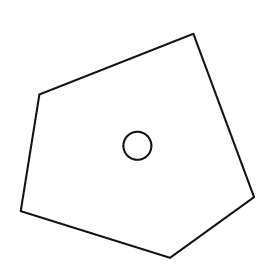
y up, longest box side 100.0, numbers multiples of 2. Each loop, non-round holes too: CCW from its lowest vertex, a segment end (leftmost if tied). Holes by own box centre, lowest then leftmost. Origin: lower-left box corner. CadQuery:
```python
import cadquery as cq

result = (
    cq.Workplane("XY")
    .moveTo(64.0, 0.0)
    .lineTo(100.0, 26.0)
    .lineTo(74.0, 96.0)
    .lineTo(8.0, 70.0)
    .lineTo(0.0, 20.0)
    .close()
    .moveTo(50.0, 48.0)
    .circle(6.0)
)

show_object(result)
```